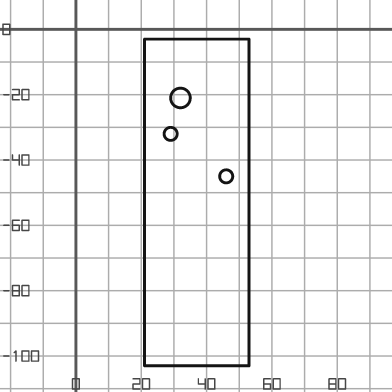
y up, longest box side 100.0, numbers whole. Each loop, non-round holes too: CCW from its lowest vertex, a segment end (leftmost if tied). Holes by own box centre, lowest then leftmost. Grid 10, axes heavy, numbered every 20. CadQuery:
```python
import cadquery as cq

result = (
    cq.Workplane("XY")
    .moveTo(21.0, -103.0)
    .lineTo(53.0, -103.0)
    .lineTo(53.0, -3.0)
    .lineTo(21.0, -3.0)
    .close()
    .moveTo(46.0, -45.0)
    .circle(2.0)
    .moveTo(29.0, -32.0)
    .circle(2.0)
    .moveTo(32.0, -21.0)
    .circle(3.0)
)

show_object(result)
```